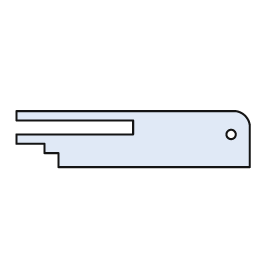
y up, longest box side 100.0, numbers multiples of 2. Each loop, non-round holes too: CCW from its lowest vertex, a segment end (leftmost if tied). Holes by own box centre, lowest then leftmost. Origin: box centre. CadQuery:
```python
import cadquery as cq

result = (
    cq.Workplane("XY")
    .moveTo(-32.0, -12.0)
    .lineTo(50.0, -12.0)
    .lineTo(50.0, 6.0)
    .threePointArc((48.0, 10.0), (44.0, 12.0))
    .lineTo(-50.0, 12.0)
    .lineTo(-50.0, 8.0)
    .lineTo(0.0, 8.0)
    .lineTo(0.0, 2.0)
    .lineTo(-50.0, 2.0)
    .lineTo(-50.0, -2.0)
    .lineTo(-38.0, -2.0)
    .lineTo(-38.0, -6.0)
    .lineTo(-32.0, -6.0)
    .close()
    .moveTo(42.0, 2.0)
    .circle(2.0)
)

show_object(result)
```